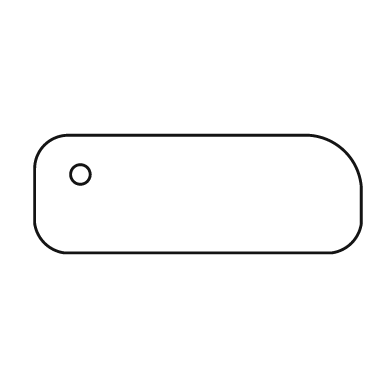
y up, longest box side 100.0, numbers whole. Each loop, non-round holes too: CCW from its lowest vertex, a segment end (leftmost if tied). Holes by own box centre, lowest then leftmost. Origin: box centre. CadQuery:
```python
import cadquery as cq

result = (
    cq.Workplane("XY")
    .moveTo(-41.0, -18.0)
    .lineTo(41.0, -18.0)
    .threePointArc((47.0, -15.0), (50.0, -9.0))
    .lineTo(50.0, 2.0)
    .threePointArc((45.0, 13.0), (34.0, 18.0))
    .lineTo(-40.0, 18.0)
    .threePointArc((-47.0, 15.0), (-50.0, 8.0))
    .lineTo(-50.0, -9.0)
    .threePointArc((-47.0, -15.0), (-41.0, -18.0))
    .close()
    .moveTo(-36.0, 6.0)
    .circle(3.0)
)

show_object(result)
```